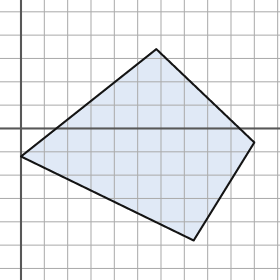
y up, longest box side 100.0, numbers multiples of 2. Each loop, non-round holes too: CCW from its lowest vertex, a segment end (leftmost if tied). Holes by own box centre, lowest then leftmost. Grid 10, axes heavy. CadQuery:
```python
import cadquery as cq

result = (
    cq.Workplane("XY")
    .moveTo(74.0, -48.0)
    .lineTo(100.0, -6.0)
    .lineTo(58.0, 34.0)
    .lineTo(0.0, -12.0)
    .close()
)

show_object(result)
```